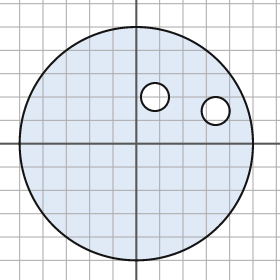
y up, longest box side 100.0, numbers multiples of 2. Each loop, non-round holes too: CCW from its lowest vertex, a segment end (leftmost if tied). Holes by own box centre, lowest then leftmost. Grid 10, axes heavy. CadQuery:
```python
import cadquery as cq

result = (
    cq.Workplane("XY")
    .moveTo(0.0, 0.0)
    .circle(50.0)
    .moveTo(34.0, 14.0)
    .circle(6.0)
    .moveTo(8.0, 20.0)
    .circle(6.0)
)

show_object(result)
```